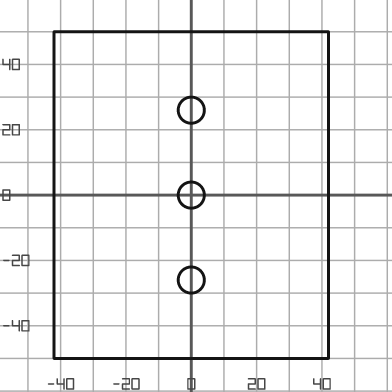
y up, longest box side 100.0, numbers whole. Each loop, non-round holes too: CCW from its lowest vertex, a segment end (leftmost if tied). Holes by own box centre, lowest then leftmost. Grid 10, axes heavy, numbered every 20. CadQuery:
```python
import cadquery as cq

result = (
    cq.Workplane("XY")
    .moveTo(-42.0, -50.0)
    .lineTo(42.0, -50.0)
    .lineTo(42.0, 50.0)
    .lineTo(-42.0, 50.0)
    .close()
    .moveTo(0.0, -26.0)
    .circle(4.0)
    .moveTo(0.0, 0.0)
    .circle(4.0)
    .moveTo(0.0, 26.0)
    .circle(4.0)
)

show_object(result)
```